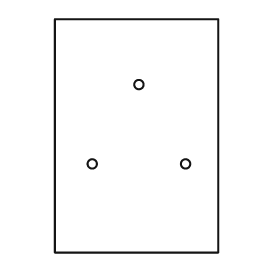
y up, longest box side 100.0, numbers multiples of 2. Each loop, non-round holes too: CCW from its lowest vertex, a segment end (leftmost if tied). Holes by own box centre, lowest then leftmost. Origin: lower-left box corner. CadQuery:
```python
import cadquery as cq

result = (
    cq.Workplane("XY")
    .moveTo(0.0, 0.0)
    .lineTo(70.0, 0.0)
    .lineTo(70.0, 100.0)
    .lineTo(0.0, 100.0)
    .close()
    .moveTo(16.0, 38.0)
    .circle(2.0)
    .moveTo(56.0, 38.0)
    .circle(2.0)
    .moveTo(36.0, 72.0)
    .circle(2.0)
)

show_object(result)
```